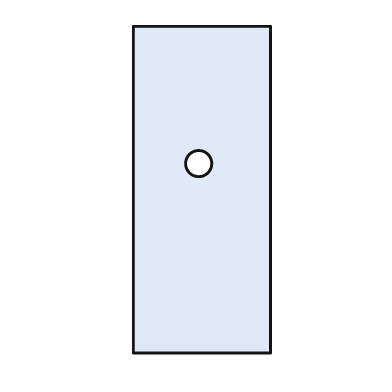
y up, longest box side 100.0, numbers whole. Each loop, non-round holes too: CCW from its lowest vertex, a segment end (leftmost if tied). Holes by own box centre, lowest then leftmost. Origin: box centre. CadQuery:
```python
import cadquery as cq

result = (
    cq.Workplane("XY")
    .moveTo(-21.0, -50.0)
    .lineTo(21.0, -50.0)
    .lineTo(21.0, 50.0)
    .lineTo(-21.0, 50.0)
    .close()
    .moveTo(-1.0, 8.0)
    .circle(4.0)
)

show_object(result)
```